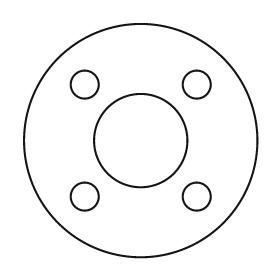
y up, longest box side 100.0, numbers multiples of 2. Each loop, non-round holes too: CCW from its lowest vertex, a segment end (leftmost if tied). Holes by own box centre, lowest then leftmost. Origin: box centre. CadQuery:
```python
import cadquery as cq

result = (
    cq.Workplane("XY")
    .moveTo(0.0, 0.0)
    .circle(50.0)
    .moveTo(-24.0, -24.0)
    .circle(6.0)
    .moveTo(24.0, -24.0)
    .circle(6.0)
    .moveTo(0.0, 0.0)
    .circle(20.0)
    .moveTo(-24.0, 24.0)
    .circle(6.0)
    .moveTo(24.0, 24.0)
    .circle(6.0)
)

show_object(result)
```